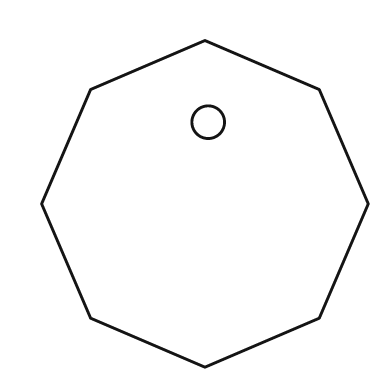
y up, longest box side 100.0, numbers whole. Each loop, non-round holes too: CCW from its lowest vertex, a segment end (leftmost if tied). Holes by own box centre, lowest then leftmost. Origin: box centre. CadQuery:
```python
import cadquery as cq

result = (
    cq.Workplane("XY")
    .moveTo(0.0, -50.0)
    .lineTo(35.0, -35.0)
    .lineTo(50.0, 0.0)
    .lineTo(35.0, 35.0)
    .lineTo(0.0, 50.0)
    .lineTo(-35.0, 35.0)
    .lineTo(-50.0, 0.0)
    .lineTo(-35.0, -35.0)
    .close()
    .moveTo(1.0, 25.0)
    .circle(5.0)
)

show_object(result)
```